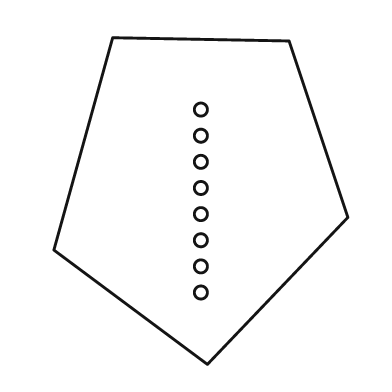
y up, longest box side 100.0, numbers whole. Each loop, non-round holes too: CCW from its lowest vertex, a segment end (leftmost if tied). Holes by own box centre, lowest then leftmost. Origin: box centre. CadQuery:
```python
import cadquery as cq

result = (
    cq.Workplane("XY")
    .moveTo(2.0, -50.0)
    .lineTo(45.0, -5.0)
    .lineTo(27.0, 49.0)
    .lineTo(-27.0, 50.0)
    .lineTo(-45.0, -15.0)
    .close()
    .moveTo(0.0, -28.0)
    .circle(2.0)
    .moveTo(0.0, -20.0)
    .circle(2.0)
    .moveTo(0.0, -12.0)
    .circle(2.0)
    .moveTo(0.0, -4.0)
    .circle(2.0)
    .moveTo(0.0, 4.0)
    .circle(2.0)
    .moveTo(0.0, 12.0)
    .circle(2.0)
    .moveTo(0.0, 20.0)
    .circle(2.0)
    .moveTo(0.0, 28.0)
    .circle(2.0)
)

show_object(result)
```